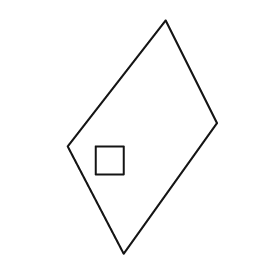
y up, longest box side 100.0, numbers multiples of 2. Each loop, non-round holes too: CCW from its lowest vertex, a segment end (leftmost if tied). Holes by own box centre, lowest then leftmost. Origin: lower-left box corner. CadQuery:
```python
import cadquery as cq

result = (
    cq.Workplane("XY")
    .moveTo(24.0, 0.0)
    .lineTo(64.0, 56.0)
    .lineTo(42.0, 100.0)
    .lineTo(0.0, 46.0)
    .close()
    .moveTo(12.0, 34.0)
    .lineTo(24.0, 34.0)
    .lineTo(24.0, 46.0)
    .lineTo(12.0, 46.0)
    .close()
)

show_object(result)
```